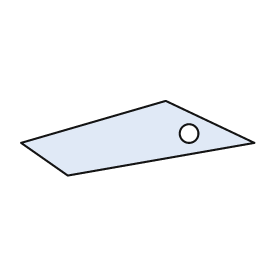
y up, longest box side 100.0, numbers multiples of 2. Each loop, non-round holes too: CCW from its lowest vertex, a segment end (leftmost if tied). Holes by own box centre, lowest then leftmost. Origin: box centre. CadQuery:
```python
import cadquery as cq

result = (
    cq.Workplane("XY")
    .moveTo(-30.0, -16.0)
    .lineTo(50.0, -2.0)
    .lineTo(12.0, 16.0)
    .lineTo(-50.0, -2.0)
    .close()
    .moveTo(22.0, 2.0)
    .circle(4.0)
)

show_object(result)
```